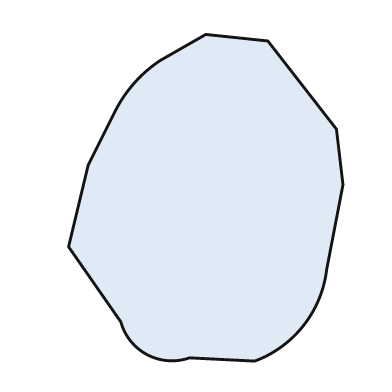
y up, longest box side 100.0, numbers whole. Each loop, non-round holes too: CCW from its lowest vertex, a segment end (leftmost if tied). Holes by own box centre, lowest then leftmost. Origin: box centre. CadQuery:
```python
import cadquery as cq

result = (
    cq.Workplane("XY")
    .moveTo(15.0, -50.0)
    .threePointArc((30.0, -39.0), (37.0, -22.0))
    .lineTo(42.0, 4.0)
    .lineTo(40.0, 21.0)
    .lineTo(19.0, 48.0)
    .lineTo(0.0, 50.0)
    .lineTo(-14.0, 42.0)
    .threePointArc((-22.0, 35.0), (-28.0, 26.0))
    .lineTo(-36.0, 10.0)
    .lineTo(-42.0, -15.0)
    .lineTo(-26.0, -38.0)
    .threePointArc((-18.0, -48.0), (-5.0, -49.0))
    .close()
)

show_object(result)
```